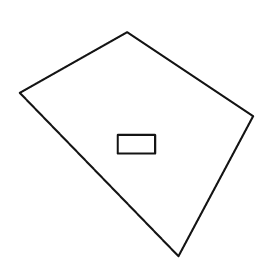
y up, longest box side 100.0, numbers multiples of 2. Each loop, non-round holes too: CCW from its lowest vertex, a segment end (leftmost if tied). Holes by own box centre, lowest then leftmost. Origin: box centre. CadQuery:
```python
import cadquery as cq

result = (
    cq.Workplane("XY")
    .moveTo(18.0, -48.0)
    .lineTo(50.0, 12.0)
    .lineTo(-4.0, 48.0)
    .lineTo(-50.0, 22.0)
    .close()
    .moveTo(-8.0, -4.0)
    .lineTo(8.0, -4.0)
    .lineTo(8.0, 4.0)
    .lineTo(-8.0, 4.0)
    .close()
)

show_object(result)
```